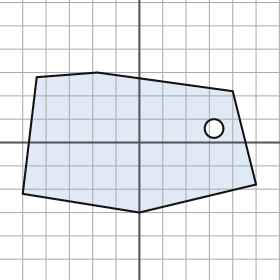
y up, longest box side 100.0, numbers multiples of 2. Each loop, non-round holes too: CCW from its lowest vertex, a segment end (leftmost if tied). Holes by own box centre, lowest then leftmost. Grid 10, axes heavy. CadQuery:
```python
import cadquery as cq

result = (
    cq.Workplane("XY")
    .moveTo(0.0, -30.0)
    .lineTo(50.0, -18.0)
    .lineTo(40.0, 22.0)
    .lineTo(-18.0, 30.0)
    .lineTo(-44.0, 28.0)
    .lineTo(-50.0, -22.0)
    .close()
    .moveTo(32.0, 6.0)
    .circle(4.0)
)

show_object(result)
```